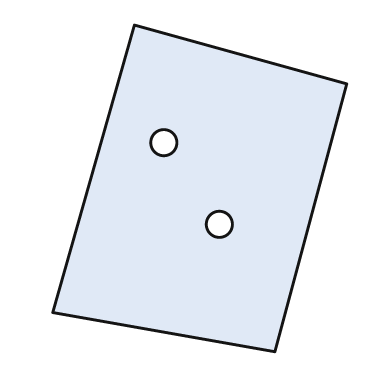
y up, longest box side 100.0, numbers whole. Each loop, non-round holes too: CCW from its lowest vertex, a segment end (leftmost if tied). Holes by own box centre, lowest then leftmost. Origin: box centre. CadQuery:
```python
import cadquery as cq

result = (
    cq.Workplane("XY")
    .moveTo(23.0, -50.0)
    .lineTo(45.0, 32.0)
    .lineTo(-20.0, 50.0)
    .lineTo(-45.0, -38.0)
    .close()
    .moveTo(6.0, -11.0)
    .circle(4.0)
    .moveTo(-11.0, 14.0)
    .circle(4.0)
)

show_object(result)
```